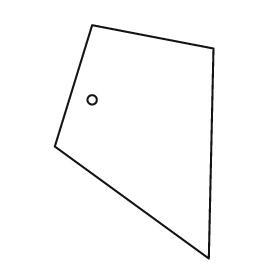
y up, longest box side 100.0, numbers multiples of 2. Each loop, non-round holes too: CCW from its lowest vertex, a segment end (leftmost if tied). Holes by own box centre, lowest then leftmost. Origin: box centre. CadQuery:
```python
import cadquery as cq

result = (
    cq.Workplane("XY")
    .moveTo(32.0, -50.0)
    .lineTo(34.0, 40.0)
    .lineTo(-18.0, 50.0)
    .lineTo(-34.0, -2.0)
    .close()
    .moveTo(-18.0, 18.0)
    .circle(2.0)
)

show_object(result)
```